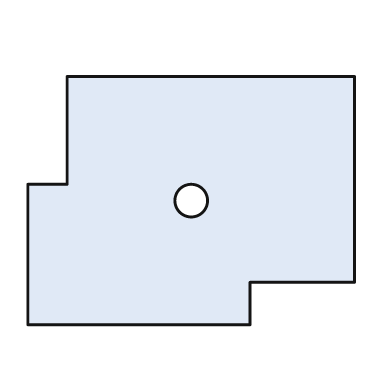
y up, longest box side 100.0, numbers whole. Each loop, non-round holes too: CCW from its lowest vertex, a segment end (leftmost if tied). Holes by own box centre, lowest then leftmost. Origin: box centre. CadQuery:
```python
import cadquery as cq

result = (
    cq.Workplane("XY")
    .moveTo(-50.0, -38.0)
    .lineTo(18.0, -38.0)
    .lineTo(18.0, -25.0)
    .lineTo(50.0, -25.0)
    .lineTo(50.0, 38.0)
    .lineTo(-38.0, 38.0)
    .lineTo(-38.0, 5.0)
    .lineTo(-50.0, 5.0)
    .close()
    .moveTo(0.0, 0.0)
    .circle(5.0)
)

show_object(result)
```